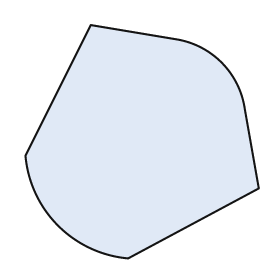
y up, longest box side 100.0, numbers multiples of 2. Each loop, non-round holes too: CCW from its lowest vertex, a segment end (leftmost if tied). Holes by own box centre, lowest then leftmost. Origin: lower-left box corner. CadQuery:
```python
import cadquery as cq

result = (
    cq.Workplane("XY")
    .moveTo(44.0, 0.0)
    .lineTo(100.0, 30.0)
    .lineTo(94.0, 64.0)
    .threePointArc((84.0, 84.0), (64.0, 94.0))
    .lineTo(28.0, 100.0)
    .lineTo(0.0, 44.0)
    .threePointArc((14.0, 14.0), (44.0, 0.0))
    .close()
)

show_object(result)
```